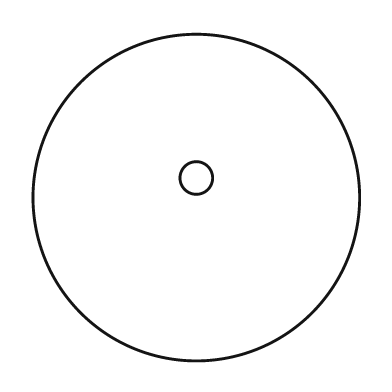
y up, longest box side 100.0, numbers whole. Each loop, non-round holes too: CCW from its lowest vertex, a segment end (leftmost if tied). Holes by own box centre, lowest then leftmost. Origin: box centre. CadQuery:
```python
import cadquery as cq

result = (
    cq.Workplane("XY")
    .moveTo(0.0, 0.0)
    .circle(50.0)
    .moveTo(0.0, 6.0)
    .circle(5.0)
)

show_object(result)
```